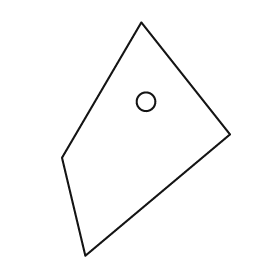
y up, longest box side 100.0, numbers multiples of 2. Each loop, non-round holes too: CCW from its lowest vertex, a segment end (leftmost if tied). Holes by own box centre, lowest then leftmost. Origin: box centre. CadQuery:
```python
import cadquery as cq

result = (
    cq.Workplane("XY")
    .moveTo(-26.0, -50.0)
    .lineTo(36.0, 2.0)
    .lineTo(-2.0, 50.0)
    .lineTo(-36.0, -8.0)
    .close()
    .moveTo(0.0, 16.0)
    .circle(4.0)
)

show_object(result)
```